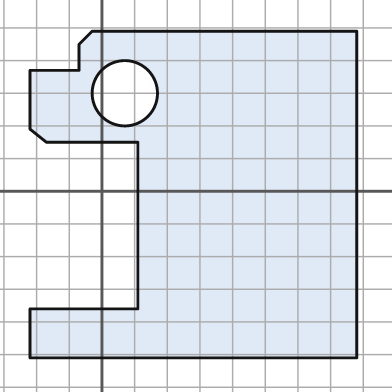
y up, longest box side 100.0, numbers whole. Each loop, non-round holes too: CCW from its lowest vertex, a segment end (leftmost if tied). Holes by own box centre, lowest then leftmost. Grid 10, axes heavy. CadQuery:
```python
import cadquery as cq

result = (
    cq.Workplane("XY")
    .moveTo(-22.0, -51.0)
    .lineTo(78.0, -51.0)
    .lineTo(78.0, 49.0)
    .lineTo(-3.0, 49.0)
    .lineTo(-7.0, 45.0)
    .lineTo(-7.0, 37.0)
    .lineTo(-22.0, 37.0)
    .lineTo(-22.0, 19.0)
    .lineTo(-17.0, 15.0)
    .lineTo(11.0, 15.0)
    .lineTo(11.0, -36.0)
    .lineTo(-22.0, -36.0)
    .close()
    .moveTo(7.0, 30.0)
    .circle(10.0)
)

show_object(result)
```